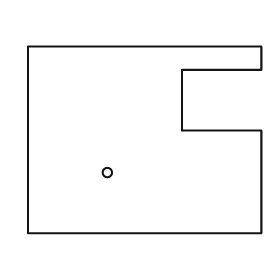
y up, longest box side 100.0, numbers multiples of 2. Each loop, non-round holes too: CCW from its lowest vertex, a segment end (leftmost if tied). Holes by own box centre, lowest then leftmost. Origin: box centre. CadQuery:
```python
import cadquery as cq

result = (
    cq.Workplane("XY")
    .moveTo(-50.0, -40.0)
    .lineTo(50.0, -40.0)
    .lineTo(50.0, 4.0)
    .lineTo(16.0, 4.0)
    .lineTo(16.0, 30.0)
    .lineTo(50.0, 30.0)
    .lineTo(50.0, 40.0)
    .lineTo(-50.0, 40.0)
    .close()
    .moveTo(-16.0, -14.0)
    .circle(2.0)
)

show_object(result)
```